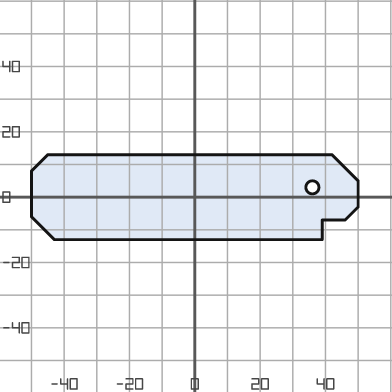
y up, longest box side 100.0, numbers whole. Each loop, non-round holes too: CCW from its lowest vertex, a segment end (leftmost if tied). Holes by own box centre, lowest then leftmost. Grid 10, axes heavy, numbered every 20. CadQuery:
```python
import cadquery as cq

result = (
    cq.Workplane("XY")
    .moveTo(-43.0, -13.0)
    .lineTo(39.0, -13.0)
    .lineTo(39.0, -7.0)
    .lineTo(46.0, -7.0)
    .lineTo(50.0, -3.0)
    .lineTo(50.0, 5.0)
    .lineTo(42.0, 13.0)
    .lineTo(-45.0, 13.0)
    .lineTo(-50.0, 8.0)
    .lineTo(-50.0, -6.0)
    .close()
    .moveTo(36.0, 3.0)
    .circle(2.0)
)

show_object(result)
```